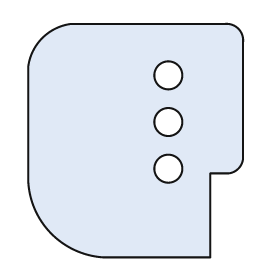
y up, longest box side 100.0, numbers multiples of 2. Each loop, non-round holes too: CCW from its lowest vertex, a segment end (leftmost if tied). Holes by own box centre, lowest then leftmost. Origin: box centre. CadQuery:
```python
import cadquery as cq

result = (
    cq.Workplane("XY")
    .moveTo(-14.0, -50.0)
    .lineTo(32.0, -50.0)
    .lineTo(32.0, -14.0)
    .lineTo(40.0, -14.0)
    .threePointArc((44.0, -12.0), (46.0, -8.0))
    .lineTo(46.0, 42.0)
    .threePointArc((44.0, 48.0), (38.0, 50.0))
    .lineTo(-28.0, 50.0)
    .threePointArc((-40.0, 44.0), (-46.0, 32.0))
    .lineTo(-46.0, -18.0)
    .threePointArc((-36.0, -40.0), (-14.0, -50.0))
    .close()
    .moveTo(14.0, -12.0)
    .circle(6.0)
    .moveTo(14.0, 8.0)
    .circle(6.0)
    .moveTo(14.0, 28.0)
    .circle(6.0)
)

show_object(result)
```